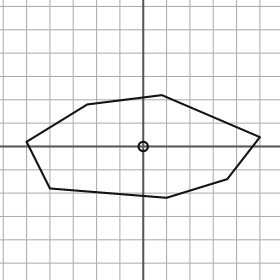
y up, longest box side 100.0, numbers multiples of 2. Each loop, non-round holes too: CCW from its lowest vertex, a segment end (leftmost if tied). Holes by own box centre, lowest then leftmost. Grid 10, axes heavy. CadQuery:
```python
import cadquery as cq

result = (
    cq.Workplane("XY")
    .moveTo(10.0, -22.0)
    .lineTo(36.0, -14.0)
    .lineTo(50.0, 4.0)
    .lineTo(8.0, 22.0)
    .lineTo(-24.0, 18.0)
    .lineTo(-50.0, 2.0)
    .lineTo(-40.0, -18.0)
    .close()
    .moveTo(0.0, 0.0)
    .circle(2.0)
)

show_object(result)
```